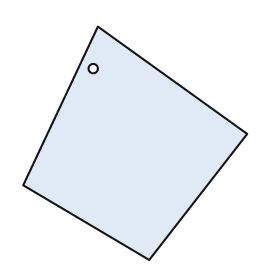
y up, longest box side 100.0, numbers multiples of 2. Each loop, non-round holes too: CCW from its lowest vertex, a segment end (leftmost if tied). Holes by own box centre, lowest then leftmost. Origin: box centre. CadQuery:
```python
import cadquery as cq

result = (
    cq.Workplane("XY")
    .moveTo(6.0, -50.0)
    .lineTo(48.0, 4.0)
    .lineTo(-16.0, 50.0)
    .lineTo(-48.0, -18.0)
    .close()
    .moveTo(-18.0, 32.0)
    .circle(2.0)
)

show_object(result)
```